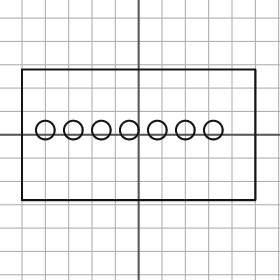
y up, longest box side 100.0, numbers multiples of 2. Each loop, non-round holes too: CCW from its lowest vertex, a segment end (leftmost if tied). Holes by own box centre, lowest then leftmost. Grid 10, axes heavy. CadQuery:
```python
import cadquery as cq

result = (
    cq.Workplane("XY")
    .moveTo(-50.0, -28.0)
    .lineTo(50.0, -28.0)
    .lineTo(50.0, 28.0)
    .lineTo(-50.0, 28.0)
    .close()
    .moveTo(-40.0, 2.0)
    .circle(4.0)
    .moveTo(-28.0, 2.0)
    .circle(4.0)
    .moveTo(-16.0, 2.0)
    .circle(4.0)
    .moveTo(-4.0, 2.0)
    .circle(4.0)
    .moveTo(8.0, 2.0)
    .circle(4.0)
    .moveTo(20.0, 2.0)
    .circle(4.0)
    .moveTo(32.0, 2.0)
    .circle(4.0)
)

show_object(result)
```